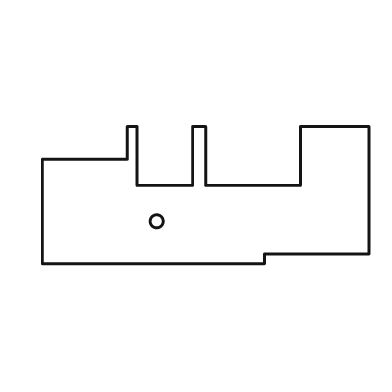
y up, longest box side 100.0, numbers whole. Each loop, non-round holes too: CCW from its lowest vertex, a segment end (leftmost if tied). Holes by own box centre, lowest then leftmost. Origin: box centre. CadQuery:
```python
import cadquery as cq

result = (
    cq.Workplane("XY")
    .moveTo(-50.0, -21.0)
    .lineTo(18.0, -21.0)
    .lineTo(18.0, -18.0)
    .lineTo(50.0, -18.0)
    .lineTo(50.0, 21.0)
    .lineTo(29.0, 21.0)
    .lineTo(29.0, 3.0)
    .lineTo(0.0, 3.0)
    .lineTo(0.0, 21.0)
    .lineTo(-4.0, 21.0)
    .lineTo(-4.0, 3.0)
    .lineTo(-21.0, 3.0)
    .lineTo(-21.0, 21.0)
    .lineTo(-24.0, 21.0)
    .lineTo(-24.0, 11.0)
    .lineTo(-50.0, 11.0)
    .close()
    .moveTo(-15.0, -8.0)
    .circle(2.0)
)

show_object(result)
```